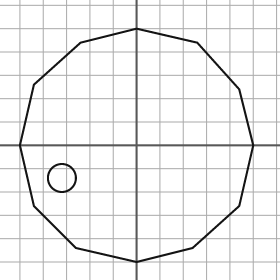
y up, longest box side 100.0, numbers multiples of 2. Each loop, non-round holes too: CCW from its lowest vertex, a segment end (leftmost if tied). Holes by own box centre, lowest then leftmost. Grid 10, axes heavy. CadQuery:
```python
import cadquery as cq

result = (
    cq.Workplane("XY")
    .moveTo(0.0, -50.0)
    .lineTo(24.0, -44.0)
    .lineTo(44.0, -26.0)
    .lineTo(50.0, 0.0)
    .lineTo(44.0, 24.0)
    .lineTo(26.0, 44.0)
    .lineTo(0.0, 50.0)
    .lineTo(-24.0, 44.0)
    .lineTo(-44.0, 26.0)
    .lineTo(-50.0, 0.0)
    .lineTo(-44.0, -26.0)
    .lineTo(-26.0, -44.0)
    .close()
    .moveTo(-32.0, -14.0)
    .circle(6.0)
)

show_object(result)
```